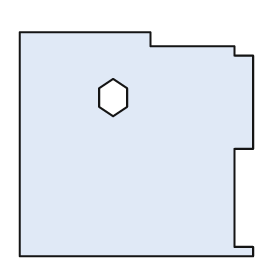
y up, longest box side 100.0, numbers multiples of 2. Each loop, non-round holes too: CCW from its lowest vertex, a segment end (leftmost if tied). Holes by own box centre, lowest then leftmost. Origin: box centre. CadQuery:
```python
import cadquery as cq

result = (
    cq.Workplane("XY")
    .moveTo(-50.0, -48.0)
    .lineTo(50.0, -48.0)
    .lineTo(50.0, -44.0)
    .lineTo(42.0, -44.0)
    .lineTo(42.0, -2.0)
    .lineTo(50.0, -2.0)
    .lineTo(50.0, 38.0)
    .lineTo(42.0, 38.0)
    .lineTo(42.0, 42.0)
    .lineTo(6.0, 42.0)
    .lineTo(6.0, 48.0)
    .lineTo(-50.0, 48.0)
    .close()
    .moveTo(-10.0, 12.0)
    .lineTo(-4.0, 16.0)
    .lineTo(-4.0, 24.0)
    .lineTo(-10.0, 28.0)
    .lineTo(-16.0, 24.0)
    .lineTo(-16.0, 16.0)
    .close()
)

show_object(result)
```